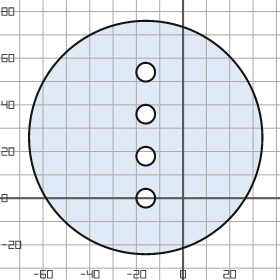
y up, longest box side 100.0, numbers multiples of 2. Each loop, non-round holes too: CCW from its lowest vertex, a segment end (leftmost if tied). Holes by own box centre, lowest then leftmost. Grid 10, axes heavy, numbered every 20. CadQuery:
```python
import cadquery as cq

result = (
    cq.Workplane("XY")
    .moveTo(-16.0, 26.0)
    .circle(50.0)
    .moveTo(-16.0, 0.0)
    .circle(4.0)
    .moveTo(-16.0, 18.0)
    .circle(4.0)
    .moveTo(-16.0, 36.0)
    .circle(4.0)
    .moveTo(-16.0, 54.0)
    .circle(4.0)
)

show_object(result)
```